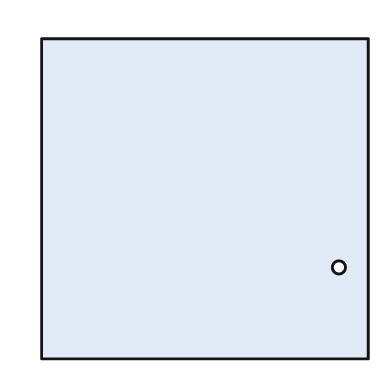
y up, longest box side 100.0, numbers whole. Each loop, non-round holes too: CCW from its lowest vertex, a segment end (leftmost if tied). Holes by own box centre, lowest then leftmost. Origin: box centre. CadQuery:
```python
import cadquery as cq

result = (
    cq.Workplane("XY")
    .moveTo(-50.0, -49.0)
    .lineTo(50.0, -49.0)
    .lineTo(50.0, 49.0)
    .lineTo(-50.0, 49.0)
    .close()
    .moveTo(41.0, -21.0)
    .circle(2.0)
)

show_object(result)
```